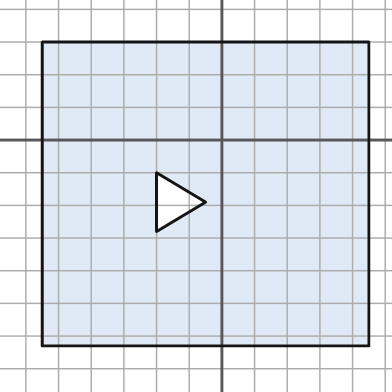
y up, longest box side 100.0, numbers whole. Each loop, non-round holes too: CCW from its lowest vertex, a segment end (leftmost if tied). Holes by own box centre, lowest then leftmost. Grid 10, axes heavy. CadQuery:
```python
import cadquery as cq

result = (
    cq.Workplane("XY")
    .moveTo(-55.0, -63.0)
    .lineTo(45.0, -63.0)
    .lineTo(45.0, 30.0)
    .lineTo(-55.0, 30.0)
    .close()
    .moveTo(-20.0, -28.0)
    .lineTo(-5.0, -19.0)
    .lineTo(-20.0, -10.0)
    .close()
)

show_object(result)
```